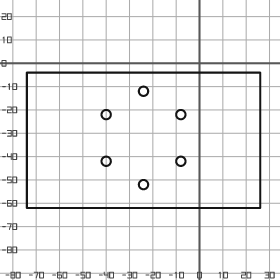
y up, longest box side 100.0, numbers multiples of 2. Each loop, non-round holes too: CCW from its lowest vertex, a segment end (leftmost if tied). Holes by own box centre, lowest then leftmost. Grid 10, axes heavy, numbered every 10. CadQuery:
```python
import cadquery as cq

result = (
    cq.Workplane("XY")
    .moveTo(-74.0, -62.0)
    .lineTo(26.0, -62.0)
    .lineTo(26.0, -4.0)
    .lineTo(-74.0, -4.0)
    .close()
    .moveTo(-24.0, -52.0)
    .circle(2.0)
    .moveTo(-40.0, -42.0)
    .circle(2.0)
    .moveTo(-8.0, -42.0)
    .circle(2.0)
    .moveTo(-40.0, -22.0)
    .circle(2.0)
    .moveTo(-8.0, -22.0)
    .circle(2.0)
    .moveTo(-24.0, -12.0)
    .circle(2.0)
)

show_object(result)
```